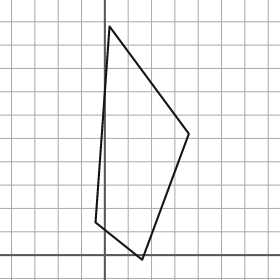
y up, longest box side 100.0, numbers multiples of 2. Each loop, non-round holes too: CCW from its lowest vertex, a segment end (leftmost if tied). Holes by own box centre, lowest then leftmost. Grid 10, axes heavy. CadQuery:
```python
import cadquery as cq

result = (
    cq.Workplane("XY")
    .moveTo(16.0, -2.0)
    .lineTo(36.0, 52.0)
    .lineTo(2.0, 98.0)
    .lineTo(-4.0, 14.0)
    .close()
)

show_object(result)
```